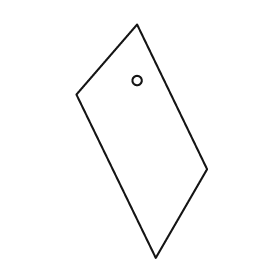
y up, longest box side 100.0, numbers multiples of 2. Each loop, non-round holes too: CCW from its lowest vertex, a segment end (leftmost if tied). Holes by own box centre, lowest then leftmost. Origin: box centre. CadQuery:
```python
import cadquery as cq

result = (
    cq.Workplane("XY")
    .moveTo(6.0, -50.0)
    .lineTo(28.0, -12.0)
    .lineTo(-2.0, 50.0)
    .lineTo(-28.0, 20.0)
    .close()
    .moveTo(-2.0, 26.0)
    .circle(2.0)
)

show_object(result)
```